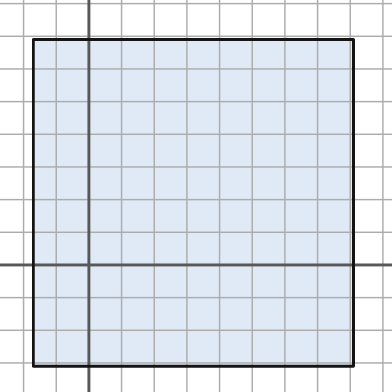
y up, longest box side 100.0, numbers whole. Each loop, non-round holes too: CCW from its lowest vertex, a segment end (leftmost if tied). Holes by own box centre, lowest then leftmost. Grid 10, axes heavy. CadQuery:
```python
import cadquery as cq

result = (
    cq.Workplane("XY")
    .moveTo(-17.0, -31.0)
    .lineTo(81.0, -31.0)
    .lineTo(81.0, 69.0)
    .lineTo(-17.0, 69.0)
    .close()
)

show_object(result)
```